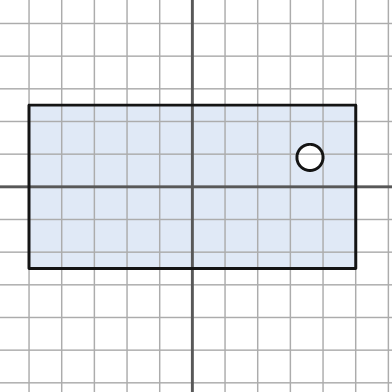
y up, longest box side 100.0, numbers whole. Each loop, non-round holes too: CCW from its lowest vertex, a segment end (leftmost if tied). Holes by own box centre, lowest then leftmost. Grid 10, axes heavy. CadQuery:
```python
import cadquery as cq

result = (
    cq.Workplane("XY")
    .moveTo(-50.0, -25.0)
    .lineTo(50.0, -25.0)
    .lineTo(50.0, 25.0)
    .lineTo(-50.0, 25.0)
    .close()
    .moveTo(36.0, 9.0)
    .circle(4.0)
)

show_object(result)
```